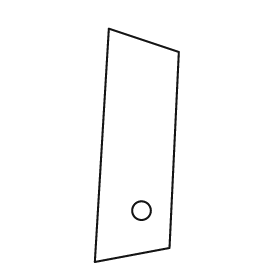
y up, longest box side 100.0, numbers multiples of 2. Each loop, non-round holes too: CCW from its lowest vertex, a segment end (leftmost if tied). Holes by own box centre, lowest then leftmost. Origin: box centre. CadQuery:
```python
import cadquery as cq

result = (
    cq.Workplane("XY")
    .moveTo(-18.0, -50.0)
    .lineTo(14.0, -44.0)
    .lineTo(18.0, 40.0)
    .lineTo(-12.0, 50.0)
    .close()
    .moveTo(2.0, -28.0)
    .circle(4.0)
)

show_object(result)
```